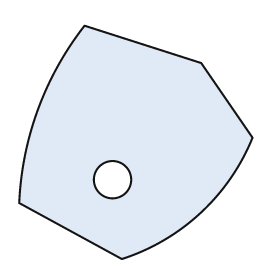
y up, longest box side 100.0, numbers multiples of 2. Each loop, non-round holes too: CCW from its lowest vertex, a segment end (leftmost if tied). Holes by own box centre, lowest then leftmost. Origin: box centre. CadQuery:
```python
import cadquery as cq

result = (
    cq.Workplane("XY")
    .moveTo(-6.0, -50.0)
    .threePointArc((28.0, -30.0), (50.0, 2.0))
    .lineTo(28.0, 34.0)
    .lineTo(-22.0, 50.0)
    .threePointArc((-42.0, 14.0), (-50.0, -26.0))
    .close()
    .moveTo(-10.0, -16.0)
    .circle(8.0)
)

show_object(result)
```